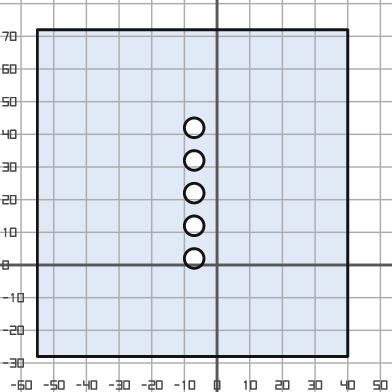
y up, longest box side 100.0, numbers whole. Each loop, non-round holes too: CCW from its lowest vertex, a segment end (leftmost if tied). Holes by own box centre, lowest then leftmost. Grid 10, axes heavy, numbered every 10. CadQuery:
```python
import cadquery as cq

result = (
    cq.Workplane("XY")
    .moveTo(-55.0, -28.0)
    .lineTo(40.0, -28.0)
    .lineTo(40.0, 72.0)
    .lineTo(-55.0, 72.0)
    .close()
    .moveTo(-7.0, 2.0)
    .circle(3.0)
    .moveTo(-7.0, 12.0)
    .circle(3.0)
    .moveTo(-7.0, 22.0)
    .circle(3.0)
    .moveTo(-7.0, 32.0)
    .circle(3.0)
    .moveTo(-7.0, 42.0)
    .circle(3.0)
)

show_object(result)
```